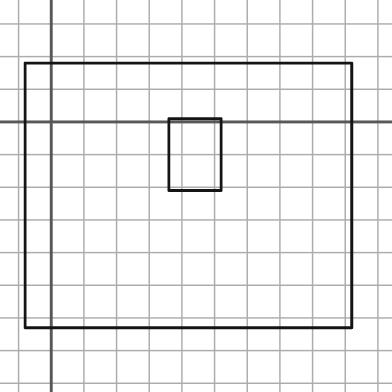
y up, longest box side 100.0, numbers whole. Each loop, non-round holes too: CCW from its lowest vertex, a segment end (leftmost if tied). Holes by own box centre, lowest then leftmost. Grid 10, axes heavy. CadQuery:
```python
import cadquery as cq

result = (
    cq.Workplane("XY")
    .moveTo(-8.0, -63.0)
    .lineTo(92.0, -63.0)
    .lineTo(92.0, 18.0)
    .lineTo(-8.0, 18.0)
    .close()
    .moveTo(36.0, -21.0)
    .lineTo(52.0, -21.0)
    .lineTo(52.0, 1.0)
    .lineTo(36.0, 1.0)
    .close()
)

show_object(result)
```